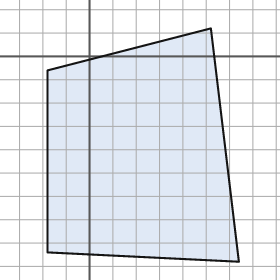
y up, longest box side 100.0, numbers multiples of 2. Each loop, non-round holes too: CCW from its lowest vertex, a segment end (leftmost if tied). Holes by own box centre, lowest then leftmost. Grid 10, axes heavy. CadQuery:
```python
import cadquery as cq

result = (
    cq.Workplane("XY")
    .moveTo(64.0, -88.0)
    .lineTo(52.0, 12.0)
    .lineTo(-18.0, -6.0)
    .lineTo(-18.0, -84.0)
    .close()
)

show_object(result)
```